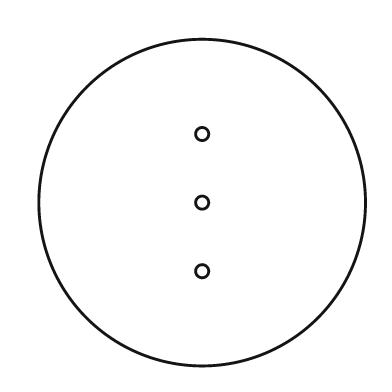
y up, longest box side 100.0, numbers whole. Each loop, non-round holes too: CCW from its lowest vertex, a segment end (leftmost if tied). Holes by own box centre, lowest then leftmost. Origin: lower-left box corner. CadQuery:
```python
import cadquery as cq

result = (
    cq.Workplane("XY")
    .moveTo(50.0, 50.0)
    .circle(50.0)
    .moveTo(50.0, 29.0)
    .circle(2.0)
    .moveTo(50.0, 50.0)
    .circle(2.0)
    .moveTo(50.0, 71.0)
    .circle(2.0)
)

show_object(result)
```